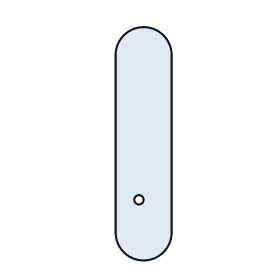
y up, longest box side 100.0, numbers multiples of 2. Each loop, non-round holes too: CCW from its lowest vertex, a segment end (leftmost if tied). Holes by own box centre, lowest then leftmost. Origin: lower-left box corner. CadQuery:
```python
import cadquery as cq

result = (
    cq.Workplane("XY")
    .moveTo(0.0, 12.0)
    .threePointArc((12.0, 0.0), (24.0, 12.0))
    .lineTo(24.0, 88.0)
    .threePointArc((12.0, 100.0), (0.0, 88.0))
    .close()
    .moveTo(10.0, 26.0)
    .circle(2.0)
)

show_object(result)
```